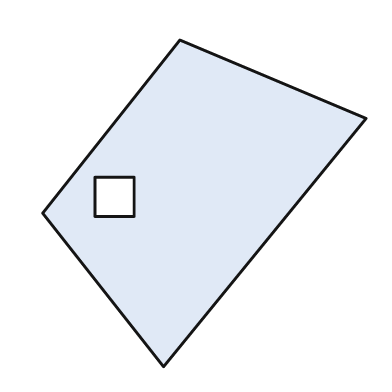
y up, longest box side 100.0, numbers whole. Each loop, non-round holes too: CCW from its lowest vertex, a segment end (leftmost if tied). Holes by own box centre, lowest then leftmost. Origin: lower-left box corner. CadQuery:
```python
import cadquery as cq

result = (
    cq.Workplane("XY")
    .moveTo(37.0, 0.0)
    .lineTo(99.0, 76.0)
    .lineTo(42.0, 100.0)
    .lineTo(0.0, 47.0)
    .close()
    .moveTo(16.0, 46.0)
    .lineTo(28.0, 46.0)
    .lineTo(28.0, 58.0)
    .lineTo(16.0, 58.0)
    .close()
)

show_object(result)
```